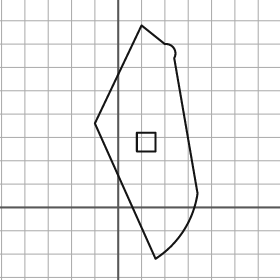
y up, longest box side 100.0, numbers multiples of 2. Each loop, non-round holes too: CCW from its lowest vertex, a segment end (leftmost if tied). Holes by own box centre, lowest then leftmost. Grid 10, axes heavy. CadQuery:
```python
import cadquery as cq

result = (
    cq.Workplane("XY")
    .moveTo(16.0, -22.0)
    .threePointArc((28.0, -10.0), (34.0, 6.0))
    .lineTo(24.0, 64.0)
    .threePointArc((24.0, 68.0), (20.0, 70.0))
    .lineTo(10.0, 78.0)
    .lineTo(-10.0, 36.0)
    .close()
    .moveTo(8.0, 24.0)
    .lineTo(16.0, 24.0)
    .lineTo(16.0, 32.0)
    .lineTo(8.0, 32.0)
    .close()
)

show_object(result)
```